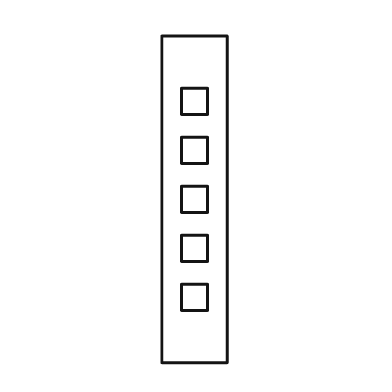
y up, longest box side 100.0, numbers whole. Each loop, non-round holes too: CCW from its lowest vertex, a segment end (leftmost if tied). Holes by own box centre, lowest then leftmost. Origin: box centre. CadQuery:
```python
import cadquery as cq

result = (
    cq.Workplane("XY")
    .moveTo(-10.0, -50.0)
    .lineTo(10.0, -50.0)
    .lineTo(10.0, 50.0)
    .lineTo(-10.0, 50.0)
    .close()
    .moveTo(-4.0, -34.0)
    .lineTo(4.0, -34.0)
    .lineTo(4.0, -26.0)
    .lineTo(-4.0, -26.0)
    .close()
    .moveTo(-4.0, -19.0)
    .lineTo(4.0, -19.0)
    .lineTo(4.0, -11.0)
    .lineTo(-4.0, -11.0)
    .close()
    .moveTo(-4.0, -4.0)
    .lineTo(4.0, -4.0)
    .lineTo(4.0, 4.0)
    .lineTo(-4.0, 4.0)
    .close()
    .moveTo(-4.0, 11.0)
    .lineTo(4.0, 11.0)
    .lineTo(4.0, 19.0)
    .lineTo(-4.0, 19.0)
    .close()
    .moveTo(-4.0, 26.0)
    .lineTo(4.0, 26.0)
    .lineTo(4.0, 34.0)
    .lineTo(-4.0, 34.0)
    .close()
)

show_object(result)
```